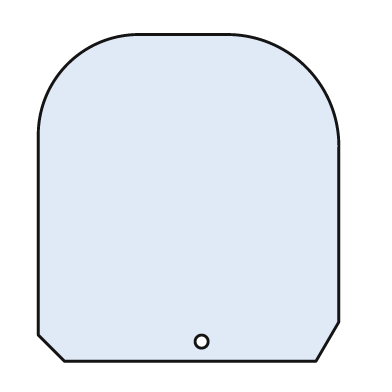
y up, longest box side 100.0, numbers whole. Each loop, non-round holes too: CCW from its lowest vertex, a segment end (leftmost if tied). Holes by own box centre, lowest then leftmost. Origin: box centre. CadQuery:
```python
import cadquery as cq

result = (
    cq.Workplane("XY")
    .moveTo(-38.0, -50.0)
    .lineTo(39.0, -50.0)
    .lineTo(46.0, -38.0)
    .lineTo(46.0, 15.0)
    .threePointArc((36.0, 40.0), (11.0, 50.0))
    .lineTo(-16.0, 50.0)
    .threePointArc((-37.0, 41.0), (-46.0, 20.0))
    .lineTo(-46.0, -42.0)
    .close()
    .moveTo(4.0, -44.0)
    .circle(2.0)
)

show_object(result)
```